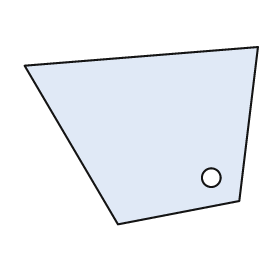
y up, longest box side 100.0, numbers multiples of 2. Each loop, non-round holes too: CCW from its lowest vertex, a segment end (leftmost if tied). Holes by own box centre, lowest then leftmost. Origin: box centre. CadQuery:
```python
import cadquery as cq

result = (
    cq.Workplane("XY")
    .moveTo(-10.0, -38.0)
    .lineTo(42.0, -28.0)
    .lineTo(50.0, 38.0)
    .lineTo(-50.0, 30.0)
    .close()
    .moveTo(30.0, -18.0)
    .circle(4.0)
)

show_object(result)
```